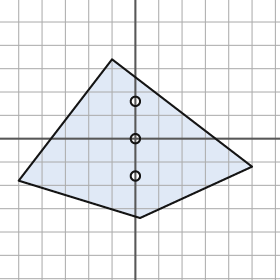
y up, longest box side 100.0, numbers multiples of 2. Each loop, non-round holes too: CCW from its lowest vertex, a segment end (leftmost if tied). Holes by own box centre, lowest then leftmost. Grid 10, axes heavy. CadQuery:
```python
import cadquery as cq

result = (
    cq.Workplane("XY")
    .moveTo(2.0, -34.0)
    .lineTo(50.0, -12.0)
    .lineTo(-10.0, 34.0)
    .lineTo(-50.0, -18.0)
    .close()
    .moveTo(0.0, -16.0)
    .circle(2.0)
    .moveTo(0.0, 0.0)
    .circle(2.0)
    .moveTo(0.0, 16.0)
    .circle(2.0)
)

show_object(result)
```